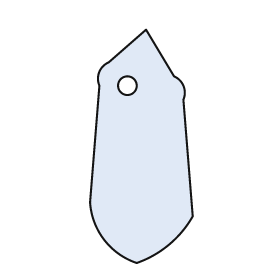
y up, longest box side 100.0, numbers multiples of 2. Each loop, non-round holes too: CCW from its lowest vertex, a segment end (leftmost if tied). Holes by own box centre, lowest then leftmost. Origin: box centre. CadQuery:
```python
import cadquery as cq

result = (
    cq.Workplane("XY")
    .moveTo(-2.0, -50.0)
    .threePointArc((12.0, -42.0), (22.0, -30.0))
    .lineTo(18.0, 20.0)
    .threePointArc((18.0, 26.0), (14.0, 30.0))
    .lineTo(2.0, 50.0)
    .lineTo(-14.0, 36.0)
    .threePointArc((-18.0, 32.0), (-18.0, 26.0))
    .lineTo(-22.0, -24.0)
    .threePointArc((-16.0, -40.0), (-2.0, -50.0))
    .close()
    .moveTo(-6.0, 26.0)
    .circle(4.0)
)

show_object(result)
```